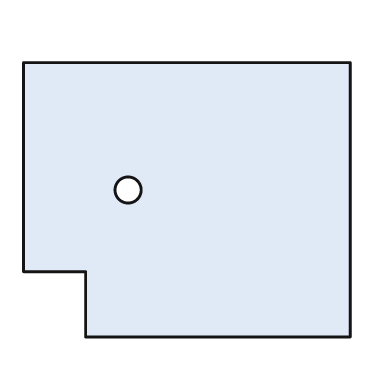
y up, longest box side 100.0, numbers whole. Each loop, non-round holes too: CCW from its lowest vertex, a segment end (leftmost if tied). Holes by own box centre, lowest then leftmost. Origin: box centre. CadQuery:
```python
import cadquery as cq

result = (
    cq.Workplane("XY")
    .moveTo(-31.0, -42.0)
    .lineTo(50.0, -42.0)
    .lineTo(50.0, 42.0)
    .lineTo(-50.0, 42.0)
    .lineTo(-50.0, -22.0)
    .lineTo(-31.0, -22.0)
    .close()
    .moveTo(-18.0, 3.0)
    .circle(4.0)
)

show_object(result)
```